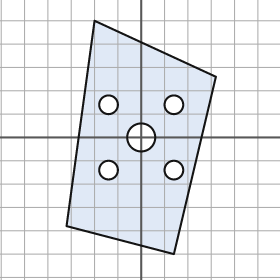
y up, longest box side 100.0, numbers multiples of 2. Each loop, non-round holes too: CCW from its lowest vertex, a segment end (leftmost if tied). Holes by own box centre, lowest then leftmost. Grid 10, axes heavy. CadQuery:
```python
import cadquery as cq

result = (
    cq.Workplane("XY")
    .moveTo(14.0, -50.0)
    .lineTo(32.0, 26.0)
    .lineTo(-20.0, 50.0)
    .lineTo(-32.0, -38.0)
    .close()
    .moveTo(-14.0, -14.0)
    .circle(4.0)
    .moveTo(14.0, -14.0)
    .circle(4.0)
    .moveTo(0.0, 0.0)
    .circle(6.0)
    .moveTo(-14.0, 14.0)
    .circle(4.0)
    .moveTo(14.0, 14.0)
    .circle(4.0)
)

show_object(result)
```